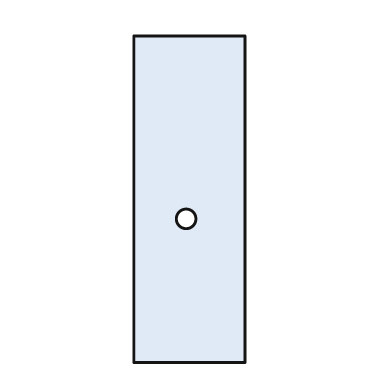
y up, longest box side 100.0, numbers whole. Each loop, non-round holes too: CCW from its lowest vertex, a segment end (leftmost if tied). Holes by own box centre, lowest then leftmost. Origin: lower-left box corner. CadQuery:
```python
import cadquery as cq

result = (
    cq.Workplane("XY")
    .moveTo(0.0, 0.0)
    .lineTo(34.0, 0.0)
    .lineTo(34.0, 100.0)
    .lineTo(0.0, 100.0)
    .close()
    .moveTo(16.0, 44.0)
    .circle(3.0)
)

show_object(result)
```